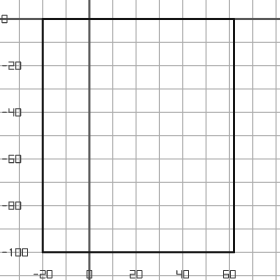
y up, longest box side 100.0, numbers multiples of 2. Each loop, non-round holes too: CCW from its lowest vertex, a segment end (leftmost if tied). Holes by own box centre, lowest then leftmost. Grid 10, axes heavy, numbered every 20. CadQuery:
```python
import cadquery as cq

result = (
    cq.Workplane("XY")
    .moveTo(-20.0, -100.0)
    .lineTo(62.0, -100.0)
    .lineTo(62.0, 0.0)
    .lineTo(-20.0, 0.0)
    .close()
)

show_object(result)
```